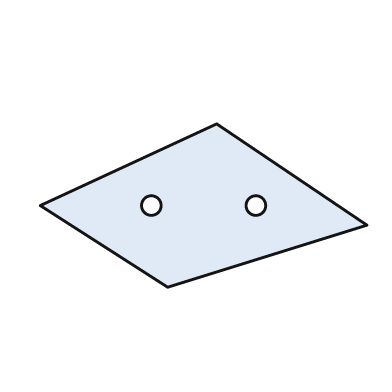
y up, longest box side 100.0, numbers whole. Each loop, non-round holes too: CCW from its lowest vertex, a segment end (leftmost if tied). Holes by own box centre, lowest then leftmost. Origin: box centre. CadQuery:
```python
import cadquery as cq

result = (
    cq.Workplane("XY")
    .moveTo(-11.0, -25.0)
    .lineTo(50.0, -6.0)
    .lineTo(4.0, 25.0)
    .lineTo(-50.0, 0.0)
    .close()
    .moveTo(-16.0, 0.0)
    .circle(3.0)
    .moveTo(16.0, 0.0)
    .circle(3.0)
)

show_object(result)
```